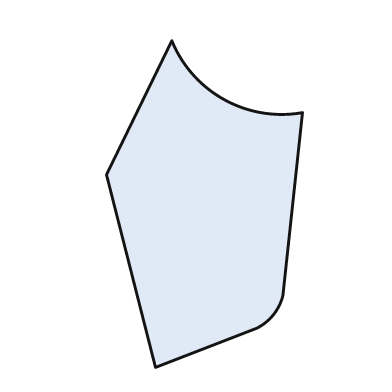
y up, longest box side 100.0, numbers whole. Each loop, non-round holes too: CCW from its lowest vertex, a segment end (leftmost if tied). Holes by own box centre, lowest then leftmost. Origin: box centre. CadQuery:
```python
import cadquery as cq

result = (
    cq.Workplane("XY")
    .moveTo(-15.0, -50.0)
    .lineTo(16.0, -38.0)
    .threePointArc((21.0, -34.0), (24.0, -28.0))
    .lineTo(30.0, 28.0)
    .threePointArc((6.0, 32.0), (-10.0, 50.0))
    .lineTo(-30.0, 9.0)
    .close()
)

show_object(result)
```